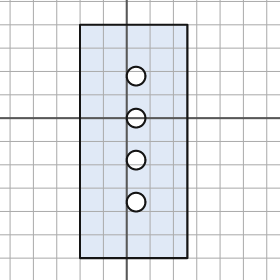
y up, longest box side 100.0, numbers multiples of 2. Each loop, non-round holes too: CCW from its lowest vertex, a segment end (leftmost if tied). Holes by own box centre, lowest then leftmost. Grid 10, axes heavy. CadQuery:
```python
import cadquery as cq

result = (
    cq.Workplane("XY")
    .moveTo(-20.0, -60.0)
    .lineTo(26.0, -60.0)
    .lineTo(26.0, 40.0)
    .lineTo(-20.0, 40.0)
    .close()
    .moveTo(4.0, -36.0)
    .circle(4.0)
    .moveTo(4.0, -18.0)
    .circle(4.0)
    .moveTo(4.0, 0.0)
    .circle(4.0)
    .moveTo(4.0, 18.0)
    .circle(4.0)
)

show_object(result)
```